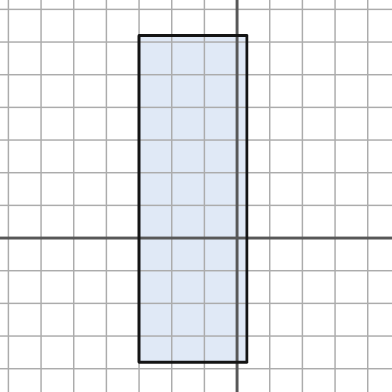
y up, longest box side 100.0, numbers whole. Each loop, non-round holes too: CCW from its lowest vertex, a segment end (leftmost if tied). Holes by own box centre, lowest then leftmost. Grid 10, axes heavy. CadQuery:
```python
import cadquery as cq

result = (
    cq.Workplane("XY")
    .moveTo(-30.0, -38.0)
    .lineTo(3.0, -38.0)
    .lineTo(3.0, 62.0)
    .lineTo(-30.0, 62.0)
    .close()
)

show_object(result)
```